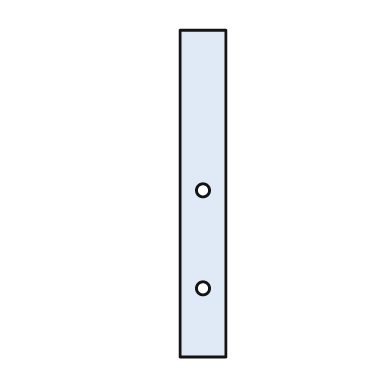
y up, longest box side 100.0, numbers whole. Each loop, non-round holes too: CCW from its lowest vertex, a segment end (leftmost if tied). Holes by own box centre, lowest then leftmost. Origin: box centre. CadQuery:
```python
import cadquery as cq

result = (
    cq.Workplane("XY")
    .moveTo(-7.0, -50.0)
    .lineTo(7.0, -50.0)
    .lineTo(7.0, 50.0)
    .lineTo(-7.0, 50.0)
    .close()
    .moveTo(0.0, -29.0)
    .circle(2.0)
    .moveTo(0.0, 1.0)
    .circle(2.0)
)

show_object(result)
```